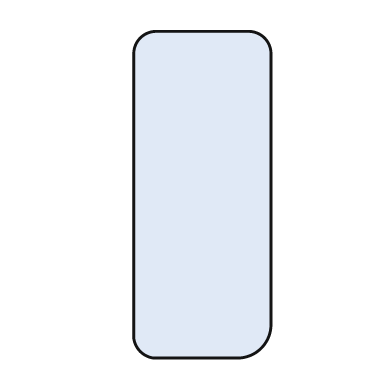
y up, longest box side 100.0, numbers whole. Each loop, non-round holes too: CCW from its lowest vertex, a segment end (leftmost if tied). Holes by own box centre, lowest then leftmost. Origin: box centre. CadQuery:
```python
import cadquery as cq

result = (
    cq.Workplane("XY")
    .moveTo(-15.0, -50.0)
    .lineTo(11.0, -50.0)
    .threePointArc((18.0, -47.0), (21.0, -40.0))
    .lineTo(21.0, 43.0)
    .threePointArc((19.0, 48.0), (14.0, 50.0))
    .lineTo(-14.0, 50.0)
    .threePointArc((-19.0, 48.0), (-21.0, 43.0))
    .lineTo(-21.0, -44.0)
    .threePointArc((-19.0, -48.0), (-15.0, -50.0))
    .close()
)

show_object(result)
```